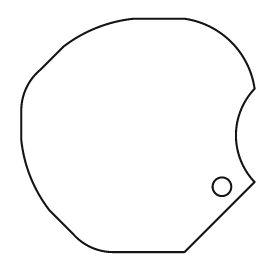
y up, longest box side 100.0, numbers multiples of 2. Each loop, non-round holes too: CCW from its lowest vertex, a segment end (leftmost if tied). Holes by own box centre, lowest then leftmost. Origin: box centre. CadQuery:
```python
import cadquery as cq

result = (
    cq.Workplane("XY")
    .moveTo(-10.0, -50.0)
    .lineTo(20.0, -50.0)
    .lineTo(50.0, -20.0)
    .threePointArc((42.0, 0.0), (50.0, 20.0))
    .threePointArc((40.0, 40.0), (20.0, 50.0))
    .lineTo(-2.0, 50.0)
    .threePointArc((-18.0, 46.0), (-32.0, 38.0))
    .lineTo(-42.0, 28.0)
    .threePointArc((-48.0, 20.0), (-50.0, 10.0))
    .lineTo(-50.0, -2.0)
    .threePointArc((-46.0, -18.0), (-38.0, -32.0))
    .lineTo(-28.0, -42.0)
    .threePointArc((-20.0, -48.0), (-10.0, -50.0))
    .close()
    .moveTo(36.0, -22.0)
    .circle(4.0)
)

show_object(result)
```